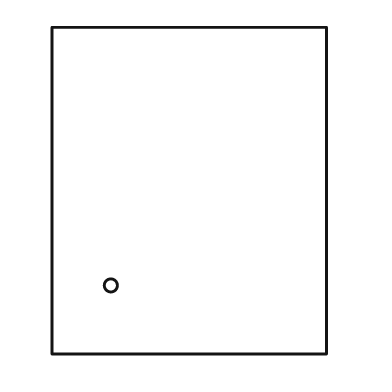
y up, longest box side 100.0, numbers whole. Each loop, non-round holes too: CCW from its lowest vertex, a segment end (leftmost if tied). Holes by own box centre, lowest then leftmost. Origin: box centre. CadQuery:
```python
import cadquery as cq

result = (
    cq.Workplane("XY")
    .moveTo(-42.0, -50.0)
    .lineTo(42.0, -50.0)
    .lineTo(42.0, 50.0)
    .lineTo(-42.0, 50.0)
    .close()
    .moveTo(-24.0, -29.0)
    .circle(2.0)
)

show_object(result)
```